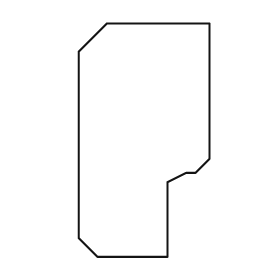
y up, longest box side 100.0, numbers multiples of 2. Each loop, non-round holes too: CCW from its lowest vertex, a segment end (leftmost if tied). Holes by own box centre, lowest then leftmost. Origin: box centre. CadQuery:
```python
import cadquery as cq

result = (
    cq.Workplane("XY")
    .moveTo(-20.0, -50.0)
    .lineTo(10.0, -50.0)
    .lineTo(10.0, -18.0)
    .lineTo(18.0, -14.0)
    .lineTo(22.0, -14.0)
    .lineTo(28.0, -8.0)
    .lineTo(28.0, 50.0)
    .lineTo(-16.0, 50.0)
    .lineTo(-28.0, 38.0)
    .lineTo(-28.0, -42.0)
    .close()
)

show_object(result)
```